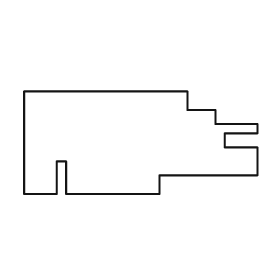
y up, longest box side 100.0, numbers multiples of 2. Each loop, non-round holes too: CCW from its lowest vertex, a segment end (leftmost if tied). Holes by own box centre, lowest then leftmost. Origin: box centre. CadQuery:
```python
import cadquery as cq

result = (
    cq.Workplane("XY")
    .moveTo(-50.0, -22.0)
    .lineTo(-36.0, -22.0)
    .lineTo(-36.0, -8.0)
    .lineTo(-32.0, -8.0)
    .lineTo(-32.0, -22.0)
    .lineTo(8.0, -22.0)
    .lineTo(8.0, -14.0)
    .lineTo(50.0, -14.0)
    .lineTo(50.0, -2.0)
    .lineTo(36.0, -2.0)
    .lineTo(36.0, 4.0)
    .lineTo(50.0, 4.0)
    .lineTo(50.0, 8.0)
    .lineTo(32.0, 8.0)
    .lineTo(32.0, 14.0)
    .lineTo(20.0, 14.0)
    .lineTo(20.0, 22.0)
    .lineTo(-50.0, 22.0)
    .close()
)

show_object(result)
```